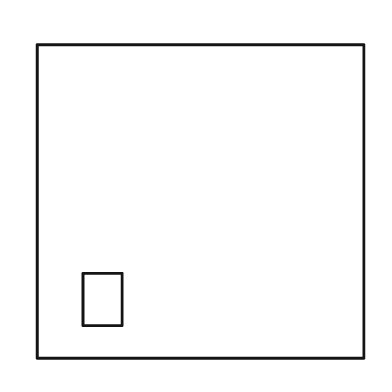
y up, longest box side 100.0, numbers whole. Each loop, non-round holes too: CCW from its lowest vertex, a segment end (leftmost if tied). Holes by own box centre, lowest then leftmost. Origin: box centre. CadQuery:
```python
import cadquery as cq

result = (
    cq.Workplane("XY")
    .moveTo(-50.0, -48.0)
    .lineTo(50.0, -48.0)
    .lineTo(50.0, 48.0)
    .lineTo(-50.0, 48.0)
    .close()
    .moveTo(-36.0, -38.0)
    .lineTo(-24.0, -38.0)
    .lineTo(-24.0, -22.0)
    .lineTo(-36.0, -22.0)
    .close()
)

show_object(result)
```